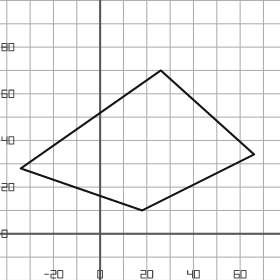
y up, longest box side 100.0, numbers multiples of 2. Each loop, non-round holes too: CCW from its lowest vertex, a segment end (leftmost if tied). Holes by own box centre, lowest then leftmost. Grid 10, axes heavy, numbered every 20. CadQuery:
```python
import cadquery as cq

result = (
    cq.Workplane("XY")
    .moveTo(18.0, 10.0)
    .lineTo(66.0, 34.0)
    .lineTo(26.0, 70.0)
    .lineTo(-34.0, 28.0)
    .close()
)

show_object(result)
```